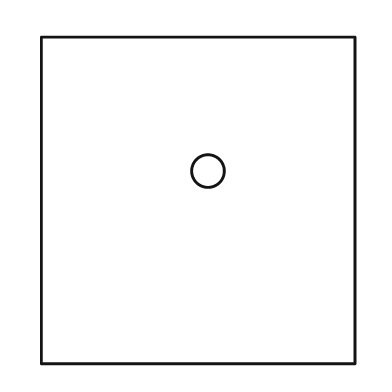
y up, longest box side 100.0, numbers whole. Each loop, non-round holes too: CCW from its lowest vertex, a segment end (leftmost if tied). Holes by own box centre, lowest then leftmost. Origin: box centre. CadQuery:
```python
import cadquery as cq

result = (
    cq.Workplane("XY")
    .moveTo(-48.0, -50.0)
    .lineTo(48.0, -50.0)
    .lineTo(48.0, 50.0)
    .lineTo(-48.0, 50.0)
    .close()
    .moveTo(3.0, 9.0)
    .circle(5.0)
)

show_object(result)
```